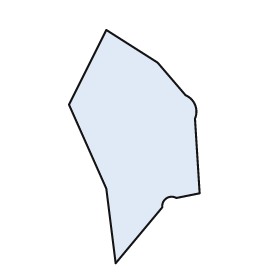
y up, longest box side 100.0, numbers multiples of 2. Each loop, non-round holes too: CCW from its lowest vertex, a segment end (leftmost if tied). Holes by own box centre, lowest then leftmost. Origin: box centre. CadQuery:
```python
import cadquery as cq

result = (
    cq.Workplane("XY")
    .moveTo(-8.0, -50.0)
    .lineTo(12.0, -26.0)
    .threePointArc((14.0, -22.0), (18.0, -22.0))
    .lineTo(28.0, -20.0)
    .lineTo(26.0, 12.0)
    .threePointArc((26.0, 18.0), (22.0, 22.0))
    .lineTo(10.0, 36.0)
    .lineTo(-12.0, 50.0)
    .lineTo(-28.0, 18.0)
    .lineTo(-12.0, -18.0)
    .close()
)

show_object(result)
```